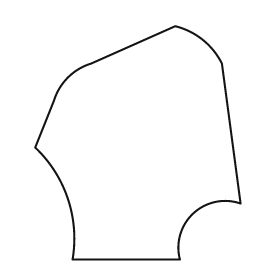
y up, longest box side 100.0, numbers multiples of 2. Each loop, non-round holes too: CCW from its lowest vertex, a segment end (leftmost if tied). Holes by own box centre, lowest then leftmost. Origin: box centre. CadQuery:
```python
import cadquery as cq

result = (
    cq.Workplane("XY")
    .moveTo(-28.0, -50.0)
    .lineTo(18.0, -50.0)
    .threePointArc((24.0, -30.0), (44.0, -26.0))
    .lineTo(36.0, 34.0)
    .threePointArc((28.0, 44.0), (16.0, 50.0))
    .lineTo(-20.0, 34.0)
    .threePointArc((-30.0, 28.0), (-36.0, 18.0))
    .lineTo(-44.0, -2.0)
    .threePointArc((-30.0, -24.0), (-28.0, -50.0))
    .close()
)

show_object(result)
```